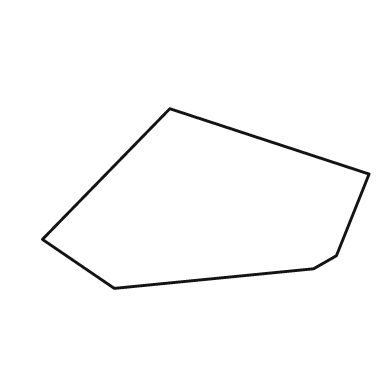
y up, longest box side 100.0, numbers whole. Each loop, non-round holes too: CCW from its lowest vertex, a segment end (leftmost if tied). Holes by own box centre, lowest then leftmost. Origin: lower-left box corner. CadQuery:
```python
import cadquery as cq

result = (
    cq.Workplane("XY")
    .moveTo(22.0, 0.0)
    .lineTo(83.0, 6.0)
    .lineTo(90.0, 10.0)
    .lineTo(100.0, 35.0)
    .lineTo(39.0, 55.0)
    .lineTo(0.0, 15.0)
    .close()
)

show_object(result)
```